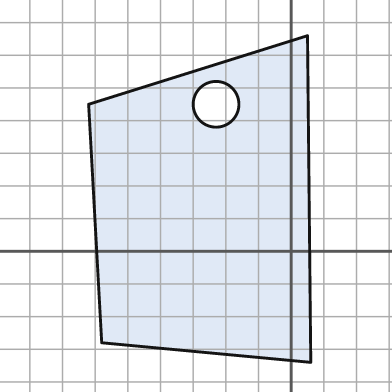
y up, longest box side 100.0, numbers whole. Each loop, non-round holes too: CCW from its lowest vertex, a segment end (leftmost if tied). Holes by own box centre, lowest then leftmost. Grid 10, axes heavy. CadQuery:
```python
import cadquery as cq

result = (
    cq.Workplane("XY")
    .moveTo(6.0, -34.0)
    .lineTo(5.0, 66.0)
    .lineTo(-62.0, 45.0)
    .lineTo(-58.0, -28.0)
    .close()
    .moveTo(-23.0, 45.0)
    .circle(7.0)
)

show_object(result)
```